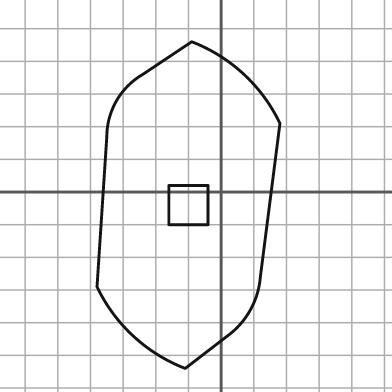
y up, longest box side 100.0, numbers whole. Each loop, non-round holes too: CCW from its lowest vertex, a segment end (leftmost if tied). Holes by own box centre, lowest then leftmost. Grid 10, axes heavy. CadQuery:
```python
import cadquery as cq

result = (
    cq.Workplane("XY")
    .moveTo(-11.0, -54.0)
    .lineTo(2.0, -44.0)
    .threePointArc((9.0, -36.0), (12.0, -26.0))
    .lineTo(18.0, 21.0)
    .threePointArc((7.0, 36.0), (-9.0, 46.0))
    .lineTo(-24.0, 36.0)
    .threePointArc((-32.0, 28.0), (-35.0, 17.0))
    .lineTo(-38.0, -29.0)
    .threePointArc((-27.0, -44.0), (-11.0, -54.0))
    .close()
    .moveTo(-16.0, -10.0)
    .lineTo(-4.0, -10.0)
    .lineTo(-4.0, 2.0)
    .lineTo(-16.0, 2.0)
    .close()
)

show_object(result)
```